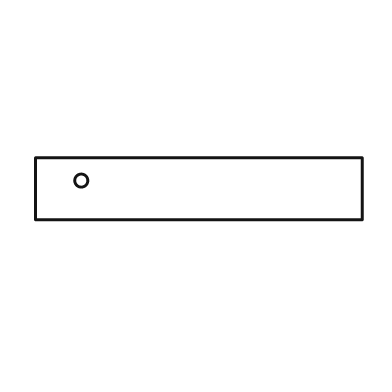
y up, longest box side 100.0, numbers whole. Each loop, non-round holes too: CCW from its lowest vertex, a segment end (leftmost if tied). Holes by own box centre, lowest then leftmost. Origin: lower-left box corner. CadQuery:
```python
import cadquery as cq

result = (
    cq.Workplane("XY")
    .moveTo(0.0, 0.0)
    .lineTo(100.0, 0.0)
    .lineTo(100.0, 19.0)
    .lineTo(0.0, 19.0)
    .close()
    .moveTo(14.0, 12.0)
    .circle(2.0)
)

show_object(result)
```